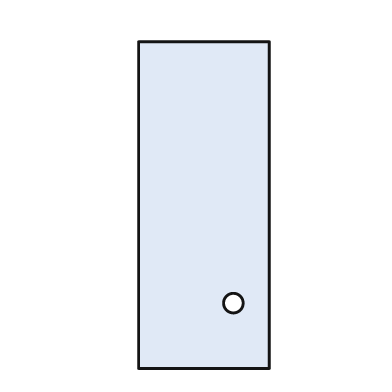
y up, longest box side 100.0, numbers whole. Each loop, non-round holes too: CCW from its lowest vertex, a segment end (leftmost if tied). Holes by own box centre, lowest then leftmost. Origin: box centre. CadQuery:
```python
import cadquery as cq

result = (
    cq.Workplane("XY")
    .moveTo(-20.0, -50.0)
    .lineTo(20.0, -50.0)
    .lineTo(20.0, 50.0)
    .lineTo(-20.0, 50.0)
    .close()
    .moveTo(9.0, -30.0)
    .circle(3.0)
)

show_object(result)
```